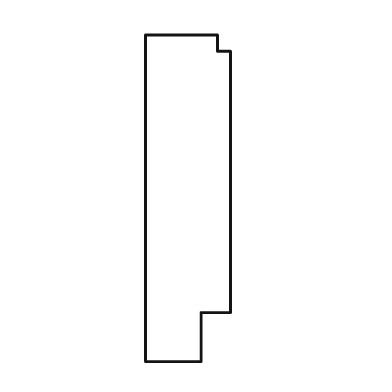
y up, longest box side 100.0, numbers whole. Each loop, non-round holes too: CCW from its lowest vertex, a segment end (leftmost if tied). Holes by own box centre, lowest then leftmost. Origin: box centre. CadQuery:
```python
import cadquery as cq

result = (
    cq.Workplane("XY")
    .moveTo(-13.0, -50.0)
    .lineTo(4.0, -50.0)
    .lineTo(4.0, -35.0)
    .lineTo(13.0, -35.0)
    .lineTo(13.0, 45.0)
    .lineTo(9.0, 45.0)
    .lineTo(9.0, 50.0)
    .lineTo(-13.0, 50.0)
    .close()
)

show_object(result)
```